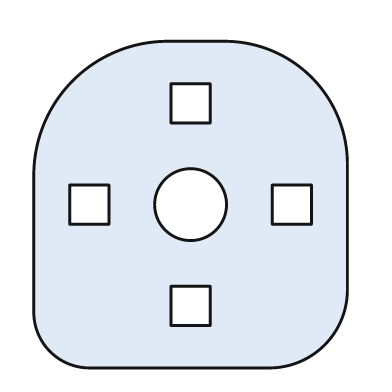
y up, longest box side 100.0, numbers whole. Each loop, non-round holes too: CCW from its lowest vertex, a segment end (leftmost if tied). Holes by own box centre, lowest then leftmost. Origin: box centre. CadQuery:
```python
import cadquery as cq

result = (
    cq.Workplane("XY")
    .moveTo(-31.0, -50.0)
    .lineTo(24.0, -50.0)
    .threePointArc((41.0, -43.0), (48.0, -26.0))
    .lineTo(48.0, 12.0)
    .threePointArc((37.0, 39.0), (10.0, 50.0))
    .lineTo(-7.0, 50.0)
    .threePointArc((-36.0, 38.0), (-48.0, 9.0))
    .lineTo(-48.0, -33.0)
    .threePointArc((-43.0, -45.0), (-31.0, -50.0))
    .close()
    .moveTo(-6.0, -37.0)
    .lineTo(6.0, -37.0)
    .lineTo(6.0, -25.0)
    .lineTo(-6.0, -25.0)
    .close()
    .moveTo(-37.0, -6.0)
    .lineTo(-25.0, -6.0)
    .lineTo(-25.0, 6.0)
    .lineTo(-37.0, 6.0)
    .close()
    .moveTo(0.0, 0.0)
    .circle(11.0)
    .moveTo(25.0, -6.0)
    .lineTo(37.0, -6.0)
    .lineTo(37.0, 6.0)
    .lineTo(25.0, 6.0)
    .close()
    .moveTo(-6.0, 25.0)
    .lineTo(6.0, 25.0)
    .lineTo(6.0, 37.0)
    .lineTo(-6.0, 37.0)
    .close()
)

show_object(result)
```